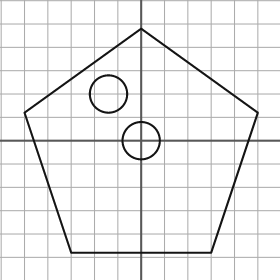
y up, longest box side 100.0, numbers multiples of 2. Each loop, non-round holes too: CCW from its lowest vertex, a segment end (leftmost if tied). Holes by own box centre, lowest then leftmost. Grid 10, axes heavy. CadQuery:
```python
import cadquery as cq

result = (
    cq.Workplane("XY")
    .moveTo(-30.0, -48.0)
    .lineTo(30.0, -48.0)
    .lineTo(50.0, 12.0)
    .lineTo(0.0, 48.0)
    .lineTo(-50.0, 12.0)
    .close()
    .moveTo(0.0, 0.0)
    .circle(8.0)
    .moveTo(-14.0, 20.0)
    .circle(8.0)
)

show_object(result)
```